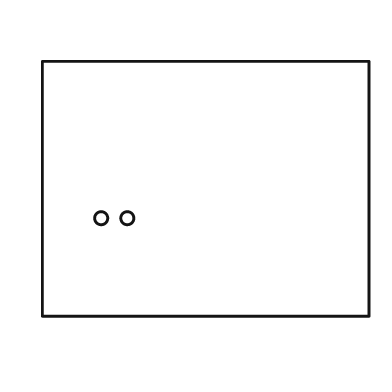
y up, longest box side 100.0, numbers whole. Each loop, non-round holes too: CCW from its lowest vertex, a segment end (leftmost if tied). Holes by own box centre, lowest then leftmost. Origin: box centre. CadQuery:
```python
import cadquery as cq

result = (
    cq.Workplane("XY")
    .moveTo(-50.0, -39.0)
    .lineTo(50.0, -39.0)
    .lineTo(50.0, 39.0)
    .lineTo(-50.0, 39.0)
    .close()
    .moveTo(-32.0, -9.0)
    .circle(2.0)
    .moveTo(-24.0, -9.0)
    .circle(2.0)
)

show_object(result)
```